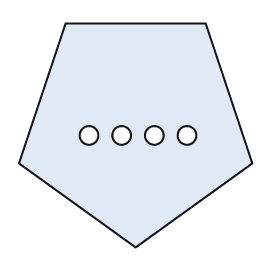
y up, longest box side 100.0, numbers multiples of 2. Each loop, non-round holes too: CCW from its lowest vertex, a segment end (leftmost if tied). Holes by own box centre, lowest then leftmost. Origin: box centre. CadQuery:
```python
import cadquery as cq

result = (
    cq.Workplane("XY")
    .moveTo(0.0, -48.0)
    .lineTo(50.0, -12.0)
    .lineTo(30.0, 48.0)
    .lineTo(-30.0, 48.0)
    .lineTo(-50.0, -12.0)
    .close()
    .moveTo(-20.0, 0.0)
    .circle(4.0)
    .moveTo(-6.0, 0.0)
    .circle(4.0)
    .moveTo(8.0, 0.0)
    .circle(4.0)
    .moveTo(22.0, 0.0)
    .circle(4.0)
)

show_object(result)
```